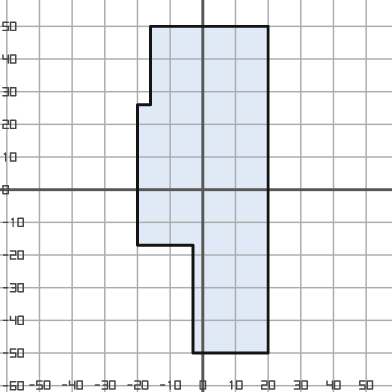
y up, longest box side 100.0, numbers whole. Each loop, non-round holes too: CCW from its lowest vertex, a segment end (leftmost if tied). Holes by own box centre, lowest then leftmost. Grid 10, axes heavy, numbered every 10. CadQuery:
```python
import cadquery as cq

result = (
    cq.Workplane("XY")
    .moveTo(-3.0, -50.0)
    .lineTo(20.0, -50.0)
    .lineTo(20.0, 50.0)
    .lineTo(-16.0, 50.0)
    .lineTo(-16.0, 26.0)
    .lineTo(-20.0, 26.0)
    .lineTo(-20.0, -17.0)
    .lineTo(-3.0, -17.0)
    .close()
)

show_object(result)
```